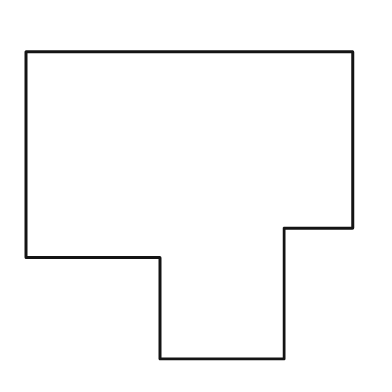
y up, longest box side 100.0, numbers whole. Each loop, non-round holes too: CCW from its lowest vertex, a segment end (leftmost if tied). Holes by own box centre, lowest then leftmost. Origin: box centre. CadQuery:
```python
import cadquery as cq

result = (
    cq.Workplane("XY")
    .moveTo(-9.0, -47.0)
    .lineTo(29.0, -47.0)
    .lineTo(29.0, -7.0)
    .lineTo(50.0, -7.0)
    .lineTo(50.0, 47.0)
    .lineTo(-50.0, 47.0)
    .lineTo(-50.0, -16.0)
    .lineTo(-9.0, -16.0)
    .close()
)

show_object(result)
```